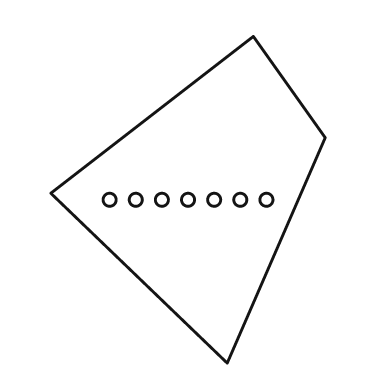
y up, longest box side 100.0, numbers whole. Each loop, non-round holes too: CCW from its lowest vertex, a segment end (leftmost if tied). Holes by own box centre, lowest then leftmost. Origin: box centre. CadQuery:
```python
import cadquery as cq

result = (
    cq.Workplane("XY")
    .moveTo(12.0, -50.0)
    .lineTo(42.0, 19.0)
    .lineTo(20.0, 50.0)
    .lineTo(-42.0, 2.0)
    .close()
    .moveTo(-24.0, 0.0)
    .circle(2.0)
    .moveTo(-16.0, 0.0)
    .circle(2.0)
    .moveTo(-8.0, 0.0)
    .circle(2.0)
    .moveTo(0.0, 0.0)
    .circle(2.0)
    .moveTo(8.0, 0.0)
    .circle(2.0)
    .moveTo(16.0, 0.0)
    .circle(2.0)
    .moveTo(24.0, 0.0)
    .circle(2.0)
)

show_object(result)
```